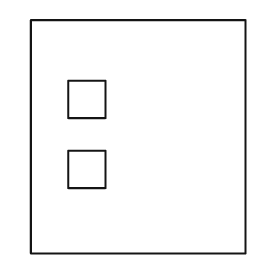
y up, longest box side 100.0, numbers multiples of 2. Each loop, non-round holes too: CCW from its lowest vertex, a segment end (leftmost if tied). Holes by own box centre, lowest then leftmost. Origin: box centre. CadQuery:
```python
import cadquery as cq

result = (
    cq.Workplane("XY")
    .moveTo(-46.0, -50.0)
    .lineTo(46.0, -50.0)
    .lineTo(46.0, 50.0)
    .lineTo(-46.0, 50.0)
    .close()
    .moveTo(-30.0, -22.0)
    .lineTo(-14.0, -22.0)
    .lineTo(-14.0, -6.0)
    .lineTo(-30.0, -6.0)
    .close()
    .moveTo(-30.0, 8.0)
    .lineTo(-14.0, 8.0)
    .lineTo(-14.0, 24.0)
    .lineTo(-30.0, 24.0)
    .close()
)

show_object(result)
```